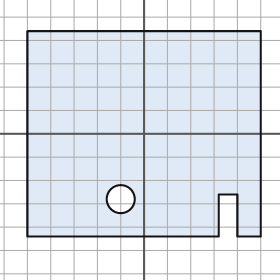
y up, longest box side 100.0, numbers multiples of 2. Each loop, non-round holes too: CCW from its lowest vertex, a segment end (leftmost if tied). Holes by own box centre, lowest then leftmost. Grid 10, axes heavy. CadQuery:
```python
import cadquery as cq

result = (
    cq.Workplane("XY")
    .moveTo(-50.0, -44.0)
    .lineTo(32.0, -44.0)
    .lineTo(32.0, -26.0)
    .lineTo(40.0, -26.0)
    .lineTo(40.0, -44.0)
    .lineTo(50.0, -44.0)
    .lineTo(50.0, 44.0)
    .lineTo(-50.0, 44.0)
    .close()
    .moveTo(-10.0, -28.0)
    .circle(6.0)
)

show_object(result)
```